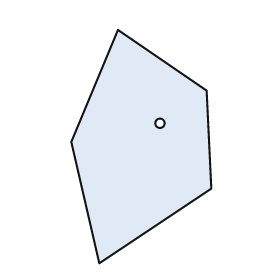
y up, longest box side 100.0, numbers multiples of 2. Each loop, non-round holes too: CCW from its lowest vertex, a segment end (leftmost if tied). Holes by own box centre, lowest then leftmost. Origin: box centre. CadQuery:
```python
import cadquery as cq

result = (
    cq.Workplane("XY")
    .moveTo(-18.0, -50.0)
    .lineTo(30.0, -18.0)
    .lineTo(28.0, 24.0)
    .lineTo(-10.0, 50.0)
    .lineTo(-30.0, 2.0)
    .close()
    .moveTo(8.0, 10.0)
    .circle(2.0)
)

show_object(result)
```